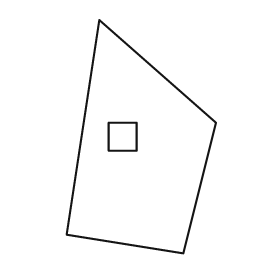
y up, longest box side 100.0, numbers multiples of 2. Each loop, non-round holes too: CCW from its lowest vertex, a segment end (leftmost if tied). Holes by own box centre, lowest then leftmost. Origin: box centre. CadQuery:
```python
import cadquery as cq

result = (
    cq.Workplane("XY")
    .moveTo(18.0, -50.0)
    .lineTo(32.0, 6.0)
    .lineTo(-18.0, 50.0)
    .lineTo(-32.0, -42.0)
    .close()
    .moveTo(-14.0, -6.0)
    .lineTo(-2.0, -6.0)
    .lineTo(-2.0, 6.0)
    .lineTo(-14.0, 6.0)
    .close()
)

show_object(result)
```